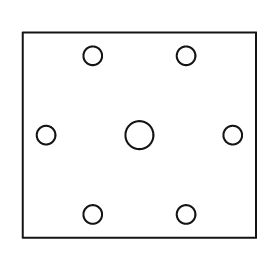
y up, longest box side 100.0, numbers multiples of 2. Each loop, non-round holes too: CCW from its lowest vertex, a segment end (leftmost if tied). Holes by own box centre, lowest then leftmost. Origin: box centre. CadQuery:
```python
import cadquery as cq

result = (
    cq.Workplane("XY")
    .moveTo(-50.0, -44.0)
    .lineTo(50.0, -44.0)
    .lineTo(50.0, 44.0)
    .lineTo(-50.0, 44.0)
    .close()
    .moveTo(-20.0, -34.0)
    .circle(4.0)
    .moveTo(20.0, -34.0)
    .circle(4.0)
    .moveTo(-40.0, 0.0)
    .circle(4.0)
    .moveTo(0.0, 0.0)
    .circle(6.0)
    .moveTo(40.0, 0.0)
    .circle(4.0)
    .moveTo(-20.0, 34.0)
    .circle(4.0)
    .moveTo(20.0, 34.0)
    .circle(4.0)
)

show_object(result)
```